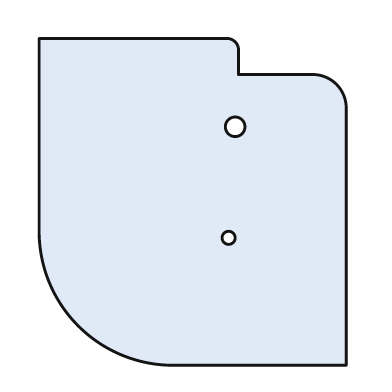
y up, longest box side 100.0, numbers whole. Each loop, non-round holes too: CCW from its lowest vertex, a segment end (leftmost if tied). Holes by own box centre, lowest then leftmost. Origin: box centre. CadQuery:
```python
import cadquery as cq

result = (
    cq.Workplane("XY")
    .moveTo(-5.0, -50.0)
    .lineTo(47.0, -50.0)
    .lineTo(47.0, 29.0)
    .threePointArc((44.0, 36.0), (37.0, 39.0))
    .lineTo(14.0, 39.0)
    .lineTo(14.0, 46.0)
    .threePointArc((13.0, 49.0), (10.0, 50.0))
    .lineTo(-47.0, 50.0)
    .lineTo(-47.0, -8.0)
    .threePointArc((-35.0, -38.0), (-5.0, -50.0))
    .close()
    .moveTo(11.0, -11.0)
    .circle(2.0)
    .moveTo(13.0, 23.0)
    .circle(3.0)
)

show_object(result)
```